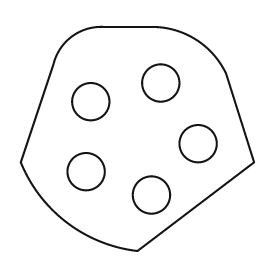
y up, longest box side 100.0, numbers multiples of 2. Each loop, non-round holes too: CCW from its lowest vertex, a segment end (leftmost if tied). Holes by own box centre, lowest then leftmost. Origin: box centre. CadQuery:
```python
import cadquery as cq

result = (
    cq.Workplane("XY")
    .moveTo(0.0, -48.0)
    .lineTo(50.0, -10.0)
    .lineTo(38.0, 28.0)
    .threePointArc((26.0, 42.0), (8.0, 48.0))
    .lineTo(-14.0, 48.0)
    .threePointArc((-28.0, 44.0), (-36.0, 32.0))
    .lineTo(-50.0, -10.0)
    .threePointArc((-30.0, -36.0), (0.0, -48.0))
    .close()
    .moveTo(6.0, -24.0)
    .circle(8.0)
    .moveTo(-22.0, -14.0)
    .circle(8.0)
    .moveTo(26.0, -2.0)
    .circle(8.0)
    .moveTo(-20.0, 16.0)
    .circle(8.0)
    .moveTo(10.0, 24.0)
    .circle(8.0)
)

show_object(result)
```